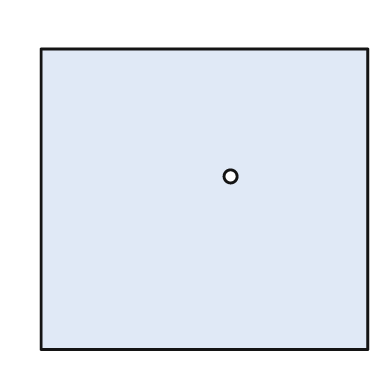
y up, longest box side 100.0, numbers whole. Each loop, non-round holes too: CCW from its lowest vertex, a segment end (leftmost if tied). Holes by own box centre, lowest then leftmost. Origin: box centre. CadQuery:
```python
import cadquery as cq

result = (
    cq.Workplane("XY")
    .moveTo(-50.0, -46.0)
    .lineTo(50.0, -46.0)
    .lineTo(50.0, 46.0)
    .lineTo(-50.0, 46.0)
    .close()
    .moveTo(8.0, 7.0)
    .circle(2.0)
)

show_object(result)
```